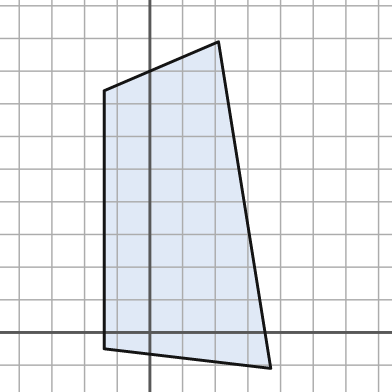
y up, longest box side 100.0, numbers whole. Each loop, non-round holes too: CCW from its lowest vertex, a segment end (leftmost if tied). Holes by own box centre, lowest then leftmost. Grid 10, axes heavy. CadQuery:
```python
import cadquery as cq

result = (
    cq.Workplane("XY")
    .moveTo(37.0, -11.0)
    .lineTo(21.0, 89.0)
    .lineTo(-14.0, 74.0)
    .lineTo(-14.0, -5.0)
    .close()
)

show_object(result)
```